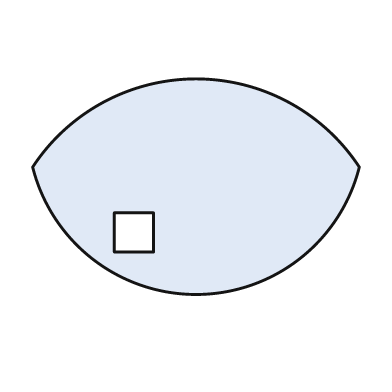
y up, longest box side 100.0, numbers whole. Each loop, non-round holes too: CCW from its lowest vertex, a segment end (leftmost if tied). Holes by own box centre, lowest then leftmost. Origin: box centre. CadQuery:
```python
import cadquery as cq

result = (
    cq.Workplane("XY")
    .moveTo(-50.0, 6.0)
    .threePointArc((0.0, -33.0), (50.0, 6.0))
    .threePointArc((0.0, 33.0), (-50.0, 6.0))
    .close()
    .moveTo(-25.0, -20.0)
    .lineTo(-13.0, -20.0)
    .lineTo(-13.0, -8.0)
    .lineTo(-25.0, -8.0)
    .close()
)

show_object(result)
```